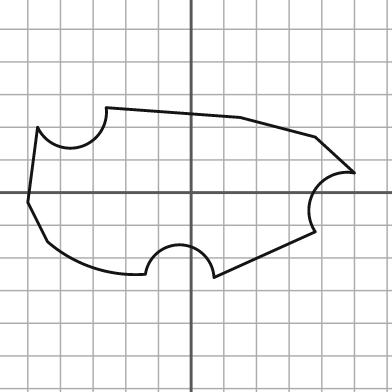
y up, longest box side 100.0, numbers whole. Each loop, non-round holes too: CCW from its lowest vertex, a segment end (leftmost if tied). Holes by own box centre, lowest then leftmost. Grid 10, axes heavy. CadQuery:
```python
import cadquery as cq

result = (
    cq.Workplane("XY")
    .moveTo(7.0, -26.0)
    .lineTo(38.0, -12.0)
    .threePointArc((38.0, 1.0), (50.0, 6.0))
    .lineTo(38.0, 17.0)
    .lineTo(15.0, 23.0)
    .lineTo(-26.0, 26.0)
    .threePointArc((-34.0, 14.0), (-47.0, 20.0))
    .lineTo(-50.0, -3.0)
    .lineTo(-44.0, -15.0)
    .threePointArc((-30.0, -23.0), (-14.0, -25.0))
    .threePointArc((-3.0, -16.0), (7.0, -26.0))
    .close()
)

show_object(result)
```